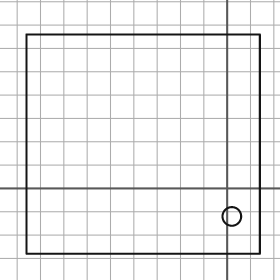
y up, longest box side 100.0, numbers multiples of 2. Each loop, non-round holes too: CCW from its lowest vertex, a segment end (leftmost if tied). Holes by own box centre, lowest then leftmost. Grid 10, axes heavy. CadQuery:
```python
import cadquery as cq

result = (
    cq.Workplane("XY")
    .moveTo(-86.0, -28.0)
    .lineTo(14.0, -28.0)
    .lineTo(14.0, 66.0)
    .lineTo(-86.0, 66.0)
    .close()
    .moveTo(2.0, -12.0)
    .circle(4.0)
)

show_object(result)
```